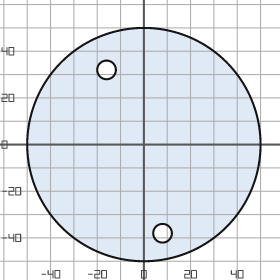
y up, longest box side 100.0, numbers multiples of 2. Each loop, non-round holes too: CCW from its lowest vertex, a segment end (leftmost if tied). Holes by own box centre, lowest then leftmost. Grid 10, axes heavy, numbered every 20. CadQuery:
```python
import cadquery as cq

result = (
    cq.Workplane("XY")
    .moveTo(0.0, 0.0)
    .circle(50.0)
    .moveTo(8.0, -38.0)
    .circle(4.0)
    .moveTo(-16.0, 32.0)
    .circle(4.0)
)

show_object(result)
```